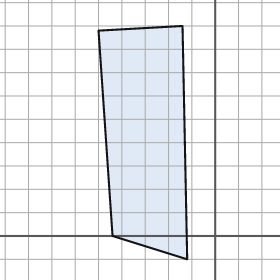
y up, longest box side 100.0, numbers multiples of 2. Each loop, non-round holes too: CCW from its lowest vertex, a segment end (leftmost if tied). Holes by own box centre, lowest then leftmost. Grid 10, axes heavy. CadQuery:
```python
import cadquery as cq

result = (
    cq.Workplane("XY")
    .moveTo(-12.0, -10.0)
    .lineTo(-14.0, 90.0)
    .lineTo(-50.0, 88.0)
    .lineTo(-44.0, 0.0)
    .close()
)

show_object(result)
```